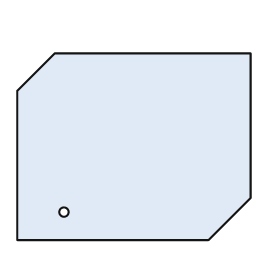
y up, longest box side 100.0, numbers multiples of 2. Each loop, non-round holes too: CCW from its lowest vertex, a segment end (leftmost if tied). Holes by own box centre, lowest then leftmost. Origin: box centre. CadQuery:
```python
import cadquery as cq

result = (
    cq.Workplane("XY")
    .moveTo(-50.0, -40.0)
    .lineTo(32.0, -40.0)
    .lineTo(50.0, -22.0)
    .lineTo(50.0, 40.0)
    .lineTo(-34.0, 40.0)
    .lineTo(-50.0, 24.0)
    .close()
    .moveTo(-30.0, -28.0)
    .circle(2.0)
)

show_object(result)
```